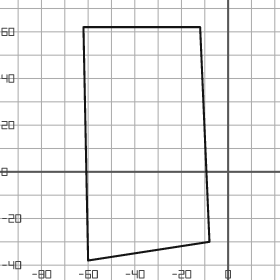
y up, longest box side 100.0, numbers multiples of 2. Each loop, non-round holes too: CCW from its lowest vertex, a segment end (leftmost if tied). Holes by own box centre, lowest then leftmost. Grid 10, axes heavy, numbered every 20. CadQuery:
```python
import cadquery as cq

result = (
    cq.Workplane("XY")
    .moveTo(-60.0, -38.0)
    .lineTo(-8.0, -30.0)
    .lineTo(-12.0, 62.0)
    .lineTo(-62.0, 62.0)
    .close()
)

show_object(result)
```